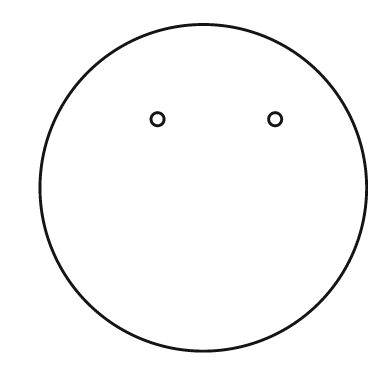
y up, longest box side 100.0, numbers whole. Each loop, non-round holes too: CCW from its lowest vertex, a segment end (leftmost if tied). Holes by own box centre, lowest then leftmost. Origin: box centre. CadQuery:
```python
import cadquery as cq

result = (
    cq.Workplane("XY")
    .moveTo(0.0, 0.0)
    .circle(50.0)
    .moveTo(-14.0, 21.0)
    .circle(2.0)
    .moveTo(22.0, 21.0)
    .circle(2.0)
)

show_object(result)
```